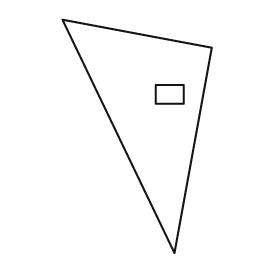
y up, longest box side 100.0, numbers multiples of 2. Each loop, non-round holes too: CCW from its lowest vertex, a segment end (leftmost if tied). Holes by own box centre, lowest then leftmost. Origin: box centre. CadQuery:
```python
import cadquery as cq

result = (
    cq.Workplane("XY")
    .moveTo(16.0, -50.0)
    .lineTo(32.0, 38.0)
    .lineTo(-32.0, 50.0)
    .close()
    .moveTo(8.0, 14.0)
    .lineTo(20.0, 14.0)
    .lineTo(20.0, 22.0)
    .lineTo(8.0, 22.0)
    .close()
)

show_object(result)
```